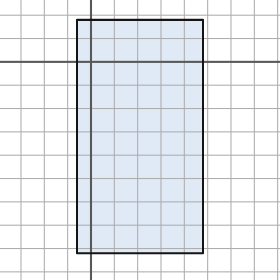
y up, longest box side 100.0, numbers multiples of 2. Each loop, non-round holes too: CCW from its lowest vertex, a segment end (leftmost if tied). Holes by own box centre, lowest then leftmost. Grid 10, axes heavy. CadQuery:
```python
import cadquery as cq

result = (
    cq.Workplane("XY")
    .moveTo(-6.0, -82.0)
    .lineTo(48.0, -82.0)
    .lineTo(48.0, 18.0)
    .lineTo(-6.0, 18.0)
    .close()
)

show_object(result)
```